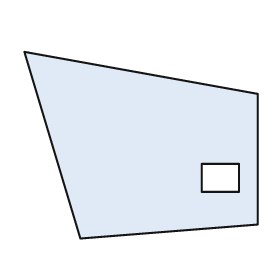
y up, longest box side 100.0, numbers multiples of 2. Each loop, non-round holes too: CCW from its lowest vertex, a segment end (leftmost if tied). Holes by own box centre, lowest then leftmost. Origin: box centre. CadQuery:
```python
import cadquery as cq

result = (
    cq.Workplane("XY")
    .moveTo(-26.0, -40.0)
    .lineTo(50.0, -34.0)
    .lineTo(50.0, 22.0)
    .lineTo(-50.0, 40.0)
    .close()
    .moveTo(26.0, -20.0)
    .lineTo(42.0, -20.0)
    .lineTo(42.0, -8.0)
    .lineTo(26.0, -8.0)
    .close()
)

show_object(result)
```